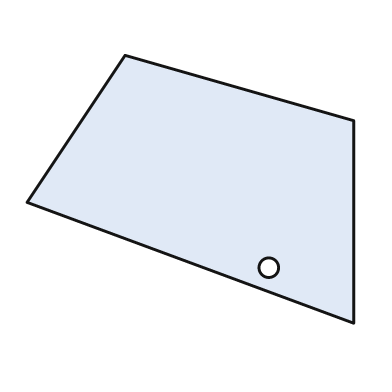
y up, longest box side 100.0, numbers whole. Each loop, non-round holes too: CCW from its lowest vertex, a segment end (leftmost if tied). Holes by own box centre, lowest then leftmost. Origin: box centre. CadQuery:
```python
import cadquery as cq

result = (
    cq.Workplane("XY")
    .moveTo(50.0, -41.0)
    .lineTo(50.0, 21.0)
    .lineTo(-20.0, 41.0)
    .lineTo(-50.0, -4.0)
    .close()
    .moveTo(24.0, -24.0)
    .circle(3.0)
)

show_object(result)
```